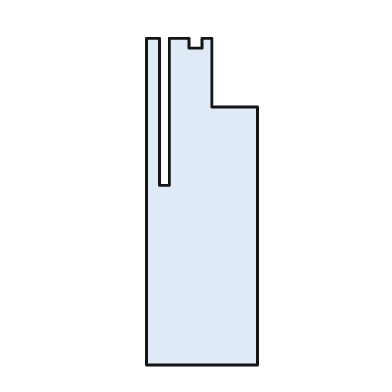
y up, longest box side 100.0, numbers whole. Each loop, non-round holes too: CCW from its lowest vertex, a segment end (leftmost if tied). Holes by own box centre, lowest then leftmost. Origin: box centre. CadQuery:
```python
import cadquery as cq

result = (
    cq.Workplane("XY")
    .moveTo(-17.0, -50.0)
    .lineTo(17.0, -50.0)
    .lineTo(17.0, 29.0)
    .lineTo(3.0, 29.0)
    .lineTo(3.0, 50.0)
    .lineTo(0.0, 50.0)
    .lineTo(0.0, 47.0)
    .lineTo(-4.0, 47.0)
    .lineTo(-4.0, 50.0)
    .lineTo(-10.0, 50.0)
    .lineTo(-10.0, 5.0)
    .lineTo(-13.0, 5.0)
    .lineTo(-13.0, 50.0)
    .lineTo(-17.0, 50.0)
    .close()
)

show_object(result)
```